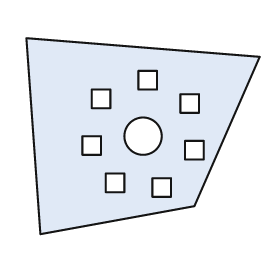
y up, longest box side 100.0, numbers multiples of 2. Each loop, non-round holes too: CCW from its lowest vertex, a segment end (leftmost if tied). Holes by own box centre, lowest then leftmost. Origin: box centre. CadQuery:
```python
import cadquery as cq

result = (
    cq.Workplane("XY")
    .moveTo(-44.0, -42.0)
    .lineTo(22.0, -30.0)
    .lineTo(50.0, 34.0)
    .lineTo(-50.0, 42.0)
    .close()
    .moveTo(4.0, -26.0)
    .lineTo(12.0, -26.0)
    .lineTo(12.0, -18.0)
    .lineTo(4.0, -18.0)
    .close()
    .moveTo(-16.0, -24.0)
    .lineTo(-8.0, -24.0)
    .lineTo(-8.0, -16.0)
    .lineTo(-16.0, -16.0)
    .close()
    .moveTo(18.0, -10.0)
    .lineTo(26.0, -10.0)
    .lineTo(26.0, -2.0)
    .lineTo(18.0, -2.0)
    .close()
    .moveTo(-26.0, -8.0)
    .lineTo(-18.0, -8.0)
    .lineTo(-18.0, 0.0)
    .lineTo(-26.0, 0.0)
    .close()
    .moveTo(0.0, 0.0)
    .circle(8.0)
    .moveTo(16.0, 10.0)
    .lineTo(24.0, 10.0)
    .lineTo(24.0, 18.0)
    .lineTo(16.0, 18.0)
    .close()
    .moveTo(-22.0, 12.0)
    .lineTo(-14.0, 12.0)
    .lineTo(-14.0, 20.0)
    .lineTo(-22.0, 20.0)
    .close()
    .moveTo(-2.0, 20.0)
    .lineTo(6.0, 20.0)
    .lineTo(6.0, 28.0)
    .lineTo(-2.0, 28.0)
    .close()
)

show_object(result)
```